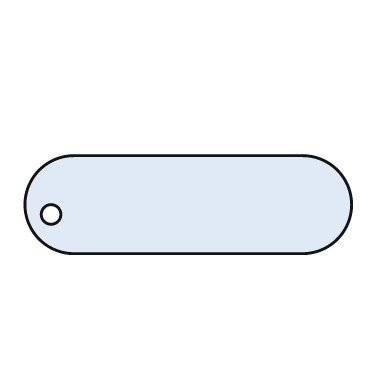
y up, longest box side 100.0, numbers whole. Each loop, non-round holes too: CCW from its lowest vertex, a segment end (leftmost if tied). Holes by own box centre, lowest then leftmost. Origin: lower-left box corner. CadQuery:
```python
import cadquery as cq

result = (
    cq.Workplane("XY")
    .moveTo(15.0, 0.0)
    .lineTo(85.0, 0.0)
    .threePointArc((100.0, 15.0), (85.0, 30.0))
    .lineTo(15.0, 30.0)
    .threePointArc((0.0, 15.0), (15.0, 0.0))
    .close()
    .moveTo(8.0, 12.0)
    .circle(3.0)
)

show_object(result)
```